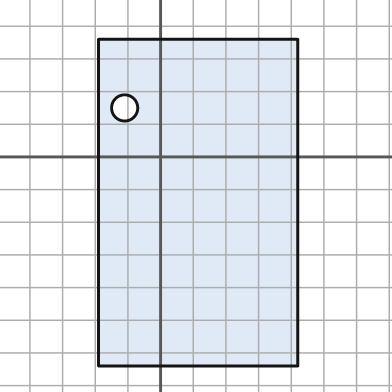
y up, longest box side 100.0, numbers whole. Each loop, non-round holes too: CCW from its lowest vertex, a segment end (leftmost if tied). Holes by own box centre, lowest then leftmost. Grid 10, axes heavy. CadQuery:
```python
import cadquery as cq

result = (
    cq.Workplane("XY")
    .moveTo(-19.0, -64.0)
    .lineTo(42.0, -64.0)
    .lineTo(42.0, 36.0)
    .lineTo(-19.0, 36.0)
    .close()
    .moveTo(-11.0, 15.0)
    .circle(4.0)
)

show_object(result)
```